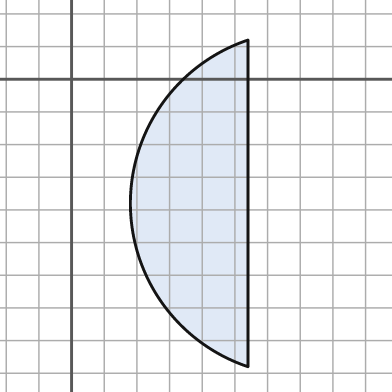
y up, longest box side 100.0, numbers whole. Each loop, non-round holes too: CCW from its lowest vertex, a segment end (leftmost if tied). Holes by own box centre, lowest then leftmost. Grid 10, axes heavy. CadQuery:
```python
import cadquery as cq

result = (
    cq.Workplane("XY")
    .moveTo(54.0, -88.0)
    .lineTo(54.0, 12.0)
    .threePointArc((18.0, -38.0), (54.0, -88.0))
    .close()
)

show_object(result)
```